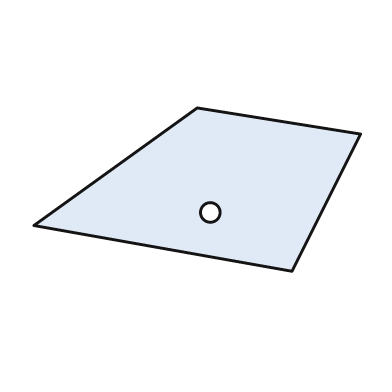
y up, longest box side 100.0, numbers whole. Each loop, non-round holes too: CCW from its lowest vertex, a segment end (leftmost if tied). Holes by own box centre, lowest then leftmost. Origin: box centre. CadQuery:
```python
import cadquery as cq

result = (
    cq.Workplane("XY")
    .moveTo(29.0, -25.0)
    .lineTo(50.0, 17.0)
    .lineTo(0.0, 25.0)
    .lineTo(-50.0, -11.0)
    .close()
    .moveTo(4.0, -7.0)
    .circle(3.0)
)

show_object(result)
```